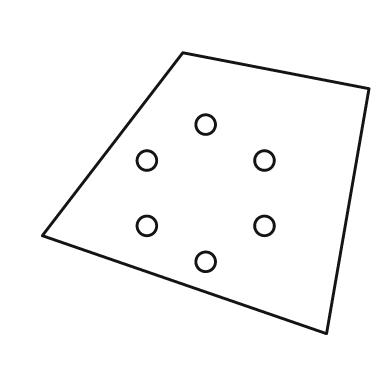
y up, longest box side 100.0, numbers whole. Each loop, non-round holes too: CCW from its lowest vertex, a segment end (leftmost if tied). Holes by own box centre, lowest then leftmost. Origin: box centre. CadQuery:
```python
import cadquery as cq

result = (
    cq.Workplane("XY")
    .moveTo(37.0, -43.0)
    .lineTo(50.0, 32.0)
    .lineTo(-7.0, 43.0)
    .lineTo(-50.0, -13.0)
    .close()
    .moveTo(0.0, -21.0)
    .circle(3.0)
    .moveTo(-18.0, -10.0)
    .circle(3.0)
    .moveTo(18.0, -10.0)
    .circle(3.0)
    .moveTo(-18.0, 10.0)
    .circle(3.0)
    .moveTo(18.0, 10.0)
    .circle(3.0)
    .moveTo(0.0, 21.0)
    .circle(3.0)
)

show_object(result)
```